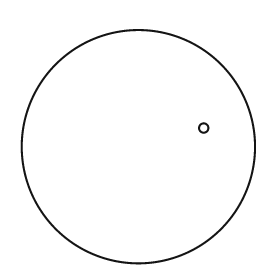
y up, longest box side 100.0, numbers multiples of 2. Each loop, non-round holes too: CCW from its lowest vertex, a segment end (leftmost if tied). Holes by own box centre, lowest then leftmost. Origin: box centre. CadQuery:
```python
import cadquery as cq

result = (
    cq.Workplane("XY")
    .moveTo(0.0, 0.0)
    .circle(50.0)
    .moveTo(28.0, 8.0)
    .circle(2.0)
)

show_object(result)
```